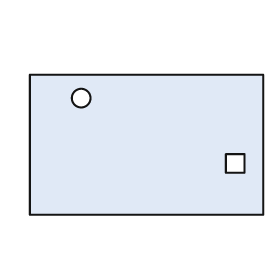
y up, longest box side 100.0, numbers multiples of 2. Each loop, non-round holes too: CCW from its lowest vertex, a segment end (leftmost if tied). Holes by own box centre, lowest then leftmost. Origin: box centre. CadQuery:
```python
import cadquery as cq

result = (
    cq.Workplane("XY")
    .moveTo(-50.0, -30.0)
    .lineTo(50.0, -30.0)
    .lineTo(50.0, 30.0)
    .lineTo(-50.0, 30.0)
    .close()
    .moveTo(34.0, -12.0)
    .lineTo(42.0, -12.0)
    .lineTo(42.0, -4.0)
    .lineTo(34.0, -4.0)
    .close()
    .moveTo(-28.0, 20.0)
    .circle(4.0)
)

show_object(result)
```